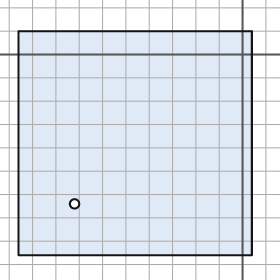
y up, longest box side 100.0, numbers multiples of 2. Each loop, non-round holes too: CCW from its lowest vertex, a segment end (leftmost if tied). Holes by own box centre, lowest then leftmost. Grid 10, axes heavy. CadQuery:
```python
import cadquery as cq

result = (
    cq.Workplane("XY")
    .moveTo(-96.0, -86.0)
    .lineTo(4.0, -86.0)
    .lineTo(4.0, 10.0)
    .lineTo(-96.0, 10.0)
    .close()
    .moveTo(-72.0, -64.0)
    .circle(2.0)
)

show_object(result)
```